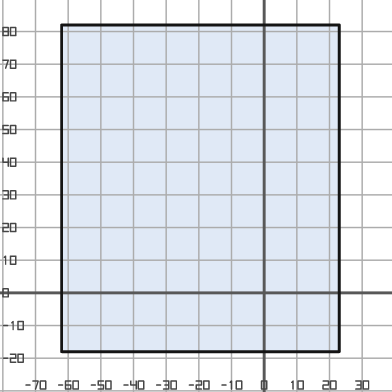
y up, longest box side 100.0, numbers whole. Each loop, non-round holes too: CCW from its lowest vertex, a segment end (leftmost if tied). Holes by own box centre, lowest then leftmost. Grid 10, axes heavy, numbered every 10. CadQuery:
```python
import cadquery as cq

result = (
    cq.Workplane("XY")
    .moveTo(-62.0, -18.0)
    .lineTo(23.0, -18.0)
    .lineTo(23.0, 82.0)
    .lineTo(-62.0, 82.0)
    .close()
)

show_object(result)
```